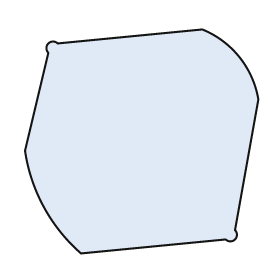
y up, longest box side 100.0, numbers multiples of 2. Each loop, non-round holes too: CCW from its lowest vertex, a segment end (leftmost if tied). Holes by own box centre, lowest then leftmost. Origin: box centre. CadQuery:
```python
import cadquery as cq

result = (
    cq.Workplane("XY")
    .moveTo(-26.0, -48.0)
    .lineTo(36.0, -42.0)
    .threePointArc((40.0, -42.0), (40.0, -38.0))
    .lineTo(50.0, 18.0)
    .threePointArc((42.0, 36.0), (26.0, 48.0))
    .lineTo(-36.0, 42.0)
    .threePointArc((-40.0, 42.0), (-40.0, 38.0))
    .lineTo(-50.0, -4.0)
    .threePointArc((-42.0, -28.0), (-26.0, -48.0))
    .close()
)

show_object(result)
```